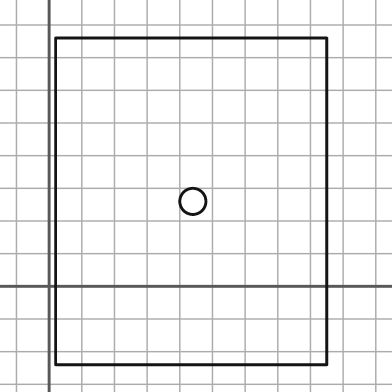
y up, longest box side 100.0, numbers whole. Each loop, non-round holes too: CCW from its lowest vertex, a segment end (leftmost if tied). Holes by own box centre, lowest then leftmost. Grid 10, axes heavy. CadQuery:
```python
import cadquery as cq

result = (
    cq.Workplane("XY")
    .moveTo(2.0, -24.0)
    .lineTo(85.0, -24.0)
    .lineTo(85.0, 76.0)
    .lineTo(2.0, 76.0)
    .close()
    .moveTo(44.0, 26.0)
    .circle(4.0)
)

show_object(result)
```